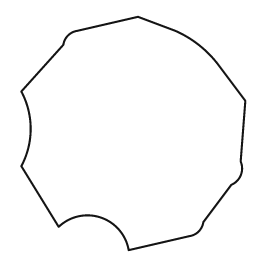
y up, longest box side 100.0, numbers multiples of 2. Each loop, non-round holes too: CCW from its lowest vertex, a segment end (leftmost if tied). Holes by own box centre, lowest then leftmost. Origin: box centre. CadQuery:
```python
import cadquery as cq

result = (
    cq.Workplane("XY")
    .moveTo(-2.0, -50.0)
    .lineTo(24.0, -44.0)
    .threePointArc((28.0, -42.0), (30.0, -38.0))
    .lineTo(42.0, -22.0)
    .threePointArc((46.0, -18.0), (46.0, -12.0))
    .lineTo(48.0, 14.0)
    .lineTo(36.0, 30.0)
    .threePointArc((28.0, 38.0), (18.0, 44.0))
    .lineTo(2.0, 50.0)
    .lineTo(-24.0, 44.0)
    .threePointArc((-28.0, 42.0), (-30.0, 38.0))
    .lineTo(-48.0, 18.0)
    .threePointArc((-44.0, 2.0), (-48.0, -14.0))
    .lineTo(-32.0, -40.0)
    .threePointArc((-14.0, -36.0), (-2.0, -50.0))
    .close()
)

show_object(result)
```